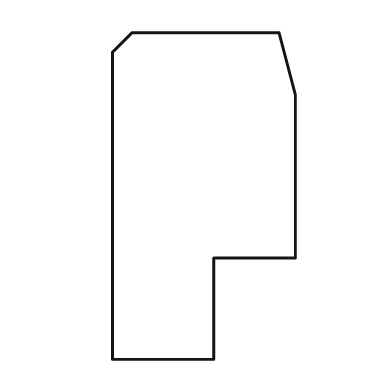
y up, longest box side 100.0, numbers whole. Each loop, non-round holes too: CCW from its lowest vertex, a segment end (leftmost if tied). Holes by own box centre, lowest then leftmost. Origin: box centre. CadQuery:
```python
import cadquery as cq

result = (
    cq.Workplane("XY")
    .moveTo(-28.0, -50.0)
    .lineTo(3.0, -50.0)
    .lineTo(3.0, -19.0)
    .lineTo(28.0, -19.0)
    .lineTo(28.0, 31.0)
    .lineTo(23.0, 50.0)
    .lineTo(-22.0, 50.0)
    .lineTo(-28.0, 44.0)
    .close()
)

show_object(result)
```